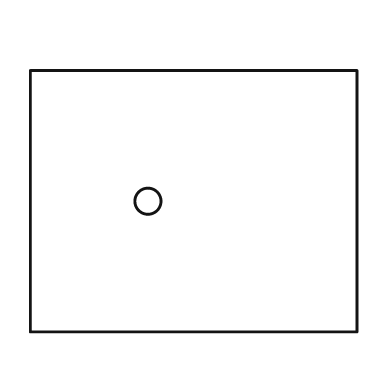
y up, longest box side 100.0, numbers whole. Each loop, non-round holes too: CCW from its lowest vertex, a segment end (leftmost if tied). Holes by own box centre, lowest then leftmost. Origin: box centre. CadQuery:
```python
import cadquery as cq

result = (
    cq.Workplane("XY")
    .moveTo(-50.0, -40.0)
    .lineTo(50.0, -40.0)
    .lineTo(50.0, 40.0)
    .lineTo(-50.0, 40.0)
    .close()
    .moveTo(-14.0, 0.0)
    .circle(4.0)
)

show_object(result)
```